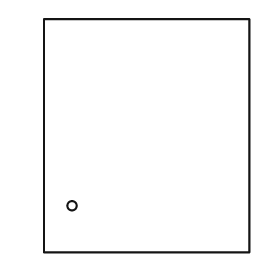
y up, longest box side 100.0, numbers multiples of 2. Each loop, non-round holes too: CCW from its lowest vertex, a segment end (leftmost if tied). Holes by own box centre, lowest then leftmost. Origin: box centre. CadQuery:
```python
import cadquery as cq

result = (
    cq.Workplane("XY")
    .moveTo(-44.0, -50.0)
    .lineTo(44.0, -50.0)
    .lineTo(44.0, 50.0)
    .lineTo(-44.0, 50.0)
    .close()
    .moveTo(-32.0, -30.0)
    .circle(2.0)
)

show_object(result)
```